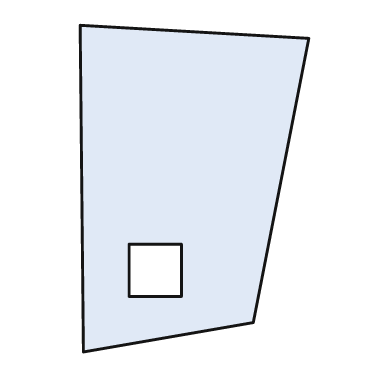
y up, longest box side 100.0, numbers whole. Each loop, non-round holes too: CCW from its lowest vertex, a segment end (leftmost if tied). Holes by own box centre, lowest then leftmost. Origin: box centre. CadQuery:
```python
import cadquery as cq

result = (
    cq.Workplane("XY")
    .moveTo(-34.0, -50.0)
    .lineTo(18.0, -41.0)
    .lineTo(35.0, 46.0)
    .lineTo(-35.0, 50.0)
    .close()
    .moveTo(-20.0, -33.0)
    .lineTo(-4.0, -33.0)
    .lineTo(-4.0, -17.0)
    .lineTo(-20.0, -17.0)
    .close()
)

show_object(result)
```